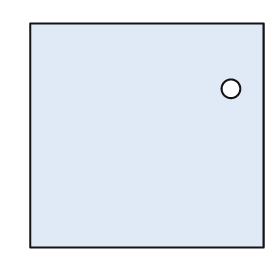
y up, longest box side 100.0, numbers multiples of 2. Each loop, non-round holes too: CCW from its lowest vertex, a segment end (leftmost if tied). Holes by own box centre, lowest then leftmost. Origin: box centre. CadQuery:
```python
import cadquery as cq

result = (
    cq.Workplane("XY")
    .moveTo(-50.0, -48.0)
    .lineTo(50.0, -48.0)
    .lineTo(50.0, 48.0)
    .lineTo(-50.0, 48.0)
    .close()
    .moveTo(36.0, 20.0)
    .circle(4.0)
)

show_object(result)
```